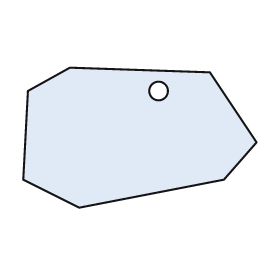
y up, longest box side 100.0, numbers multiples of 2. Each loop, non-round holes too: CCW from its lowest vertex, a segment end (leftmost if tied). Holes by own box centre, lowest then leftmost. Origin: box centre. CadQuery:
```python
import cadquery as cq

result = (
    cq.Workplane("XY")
    .moveTo(-26.0, -30.0)
    .lineTo(36.0, -18.0)
    .lineTo(50.0, -2.0)
    .lineTo(30.0, 28.0)
    .lineTo(-30.0, 30.0)
    .lineTo(-48.0, 20.0)
    .lineTo(-50.0, -18.0)
    .close()
    .moveTo(8.0, 20.0)
    .circle(4.0)
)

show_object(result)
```